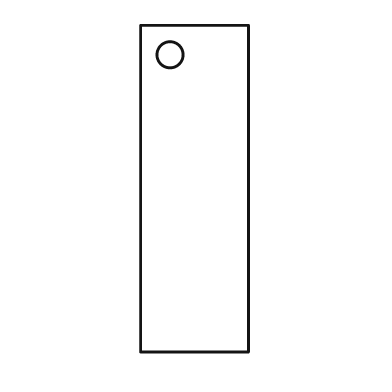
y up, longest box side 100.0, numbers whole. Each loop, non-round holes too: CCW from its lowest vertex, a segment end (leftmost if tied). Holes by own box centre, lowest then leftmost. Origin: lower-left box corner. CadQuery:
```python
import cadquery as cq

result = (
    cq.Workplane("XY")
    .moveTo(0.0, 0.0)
    .lineTo(33.0, 0.0)
    .lineTo(33.0, 100.0)
    .lineTo(0.0, 100.0)
    .close()
    .moveTo(9.0, 91.0)
    .circle(4.0)
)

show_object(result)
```